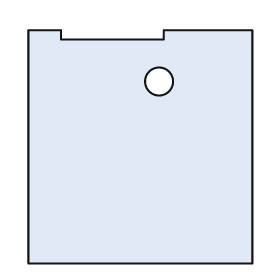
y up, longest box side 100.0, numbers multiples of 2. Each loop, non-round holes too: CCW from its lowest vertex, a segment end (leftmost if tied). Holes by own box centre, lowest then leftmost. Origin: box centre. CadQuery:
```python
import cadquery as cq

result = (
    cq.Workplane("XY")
    .moveTo(-48.0, -50.0)
    .lineTo(48.0, -50.0)
    .lineTo(48.0, 50.0)
    .lineTo(10.0, 50.0)
    .lineTo(10.0, 46.0)
    .lineTo(-34.0, 46.0)
    .lineTo(-34.0, 50.0)
    .lineTo(-48.0, 50.0)
    .close()
    .moveTo(8.0, 28.0)
    .circle(6.0)
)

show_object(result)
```